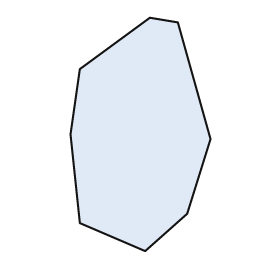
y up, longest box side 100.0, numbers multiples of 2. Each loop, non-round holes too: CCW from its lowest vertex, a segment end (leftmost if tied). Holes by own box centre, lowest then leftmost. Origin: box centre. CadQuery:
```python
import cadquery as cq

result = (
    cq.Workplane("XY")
    .moveTo(2.0, -50.0)
    .lineTo(20.0, -34.0)
    .lineTo(30.0, -2.0)
    .lineTo(16.0, 48.0)
    .lineTo(4.0, 50.0)
    .lineTo(-26.0, 28.0)
    .lineTo(-30.0, 0.0)
    .lineTo(-26.0, -38.0)
    .close()
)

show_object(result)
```